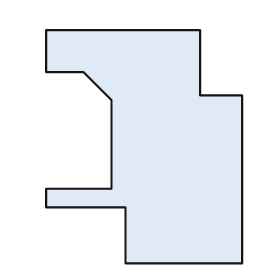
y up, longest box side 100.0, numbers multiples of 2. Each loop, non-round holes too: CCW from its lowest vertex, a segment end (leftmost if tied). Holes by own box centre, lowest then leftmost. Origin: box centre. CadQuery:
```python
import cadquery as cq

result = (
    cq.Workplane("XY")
    .moveTo(-8.0, -50.0)
    .lineTo(42.0, -50.0)
    .lineTo(42.0, 22.0)
    .lineTo(24.0, 22.0)
    .lineTo(24.0, 50.0)
    .lineTo(-42.0, 50.0)
    .lineTo(-42.0, 32.0)
    .lineTo(-26.0, 32.0)
    .lineTo(-14.0, 20.0)
    .lineTo(-14.0, -18.0)
    .lineTo(-42.0, -18.0)
    .lineTo(-42.0, -26.0)
    .lineTo(-8.0, -26.0)
    .close()
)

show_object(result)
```